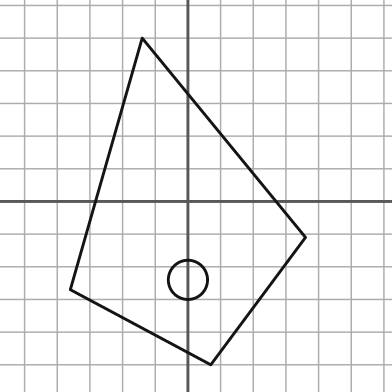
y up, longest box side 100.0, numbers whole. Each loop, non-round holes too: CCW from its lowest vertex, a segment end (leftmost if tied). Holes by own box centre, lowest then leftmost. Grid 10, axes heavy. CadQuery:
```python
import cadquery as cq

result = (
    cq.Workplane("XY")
    .moveTo(7.0, -50.0)
    .lineTo(36.0, -11.0)
    .lineTo(-14.0, 50.0)
    .lineTo(-36.0, -27.0)
    .close()
    .moveTo(0.0, -24.0)
    .circle(6.0)
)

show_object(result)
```